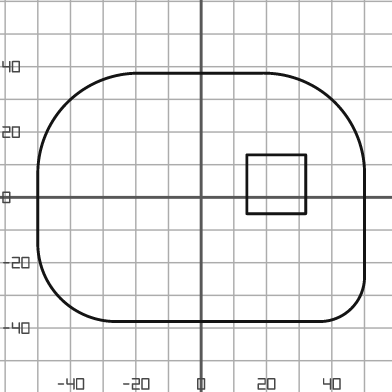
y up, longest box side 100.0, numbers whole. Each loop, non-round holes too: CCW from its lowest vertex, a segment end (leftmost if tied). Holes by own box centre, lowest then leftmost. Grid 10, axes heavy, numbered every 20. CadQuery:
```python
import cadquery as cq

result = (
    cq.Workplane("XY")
    .moveTo(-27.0, -38.0)
    .lineTo(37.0, -38.0)
    .threePointArc((46.0, -34.0), (50.0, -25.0))
    .lineTo(50.0, 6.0)
    .threePointArc((41.0, 29.0), (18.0, 38.0))
    .lineTo(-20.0, 38.0)
    .threePointArc((-41.0, 29.0), (-50.0, 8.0))
    .lineTo(-50.0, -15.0)
    .threePointArc((-43.0, -31.0), (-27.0, -38.0))
    .close()
    .moveTo(14.0, -5.0)
    .lineTo(32.0, -5.0)
    .lineTo(32.0, 13.0)
    .lineTo(14.0, 13.0)
    .close()
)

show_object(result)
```